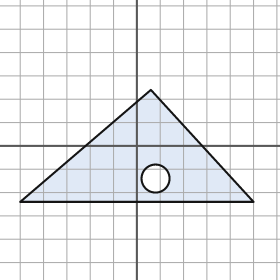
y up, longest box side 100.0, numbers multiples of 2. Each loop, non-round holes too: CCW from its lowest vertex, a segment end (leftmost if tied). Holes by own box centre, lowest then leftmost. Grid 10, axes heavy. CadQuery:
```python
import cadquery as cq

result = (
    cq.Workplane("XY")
    .moveTo(-50.0, -24.0)
    .lineTo(50.0, -24.0)
    .lineTo(6.0, 24.0)
    .close()
    .moveTo(8.0, -14.0)
    .circle(6.0)
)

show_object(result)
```